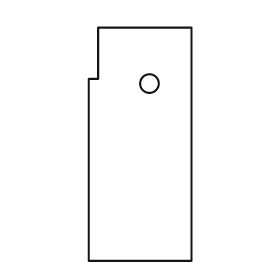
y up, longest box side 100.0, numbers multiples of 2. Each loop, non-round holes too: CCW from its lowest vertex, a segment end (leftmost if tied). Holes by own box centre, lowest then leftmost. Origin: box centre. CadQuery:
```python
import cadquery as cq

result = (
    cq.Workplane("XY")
    .moveTo(-22.0, -50.0)
    .lineTo(22.0, -50.0)
    .lineTo(22.0, 50.0)
    .lineTo(-18.0, 50.0)
    .lineTo(-18.0, 28.0)
    .lineTo(-22.0, 28.0)
    .close()
    .moveTo(4.0, 26.0)
    .circle(4.0)
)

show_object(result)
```